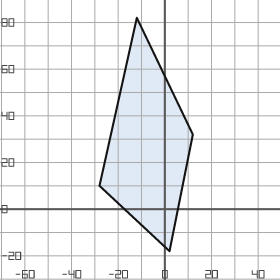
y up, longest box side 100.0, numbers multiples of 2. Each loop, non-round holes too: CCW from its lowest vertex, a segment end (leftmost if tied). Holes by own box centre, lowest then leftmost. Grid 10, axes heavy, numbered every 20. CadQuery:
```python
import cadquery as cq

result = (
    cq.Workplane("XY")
    .moveTo(2.0, -18.0)
    .lineTo(12.0, 32.0)
    .lineTo(-12.0, 82.0)
    .lineTo(-28.0, 10.0)
    .close()
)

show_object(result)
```